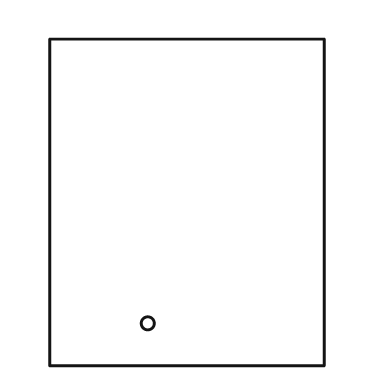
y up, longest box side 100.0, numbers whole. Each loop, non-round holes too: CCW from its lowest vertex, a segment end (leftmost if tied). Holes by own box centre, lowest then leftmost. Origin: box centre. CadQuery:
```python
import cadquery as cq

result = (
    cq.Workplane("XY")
    .moveTo(-42.0, -50.0)
    .lineTo(42.0, -50.0)
    .lineTo(42.0, 50.0)
    .lineTo(-42.0, 50.0)
    .close()
    .moveTo(-12.0, -37.0)
    .circle(2.0)
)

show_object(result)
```